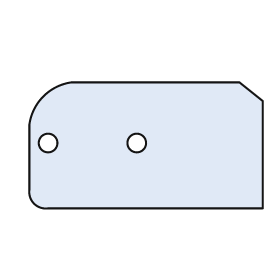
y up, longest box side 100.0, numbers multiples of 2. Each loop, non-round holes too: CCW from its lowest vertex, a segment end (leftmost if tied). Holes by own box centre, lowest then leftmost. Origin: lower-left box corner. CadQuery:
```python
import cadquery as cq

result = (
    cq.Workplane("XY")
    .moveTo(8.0, 0.0)
    .lineTo(100.0, 0.0)
    .lineTo(100.0, 46.0)
    .lineTo(90.0, 54.0)
    .lineTo(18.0, 54.0)
    .threePointArc((6.0, 48.0), (0.0, 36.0))
    .lineTo(0.0, 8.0)
    .threePointArc((2.0, 2.0), (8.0, 0.0))
    .close()
    .moveTo(8.0, 28.0)
    .circle(4.0)
    .moveTo(46.0, 28.0)
    .circle(4.0)
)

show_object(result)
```